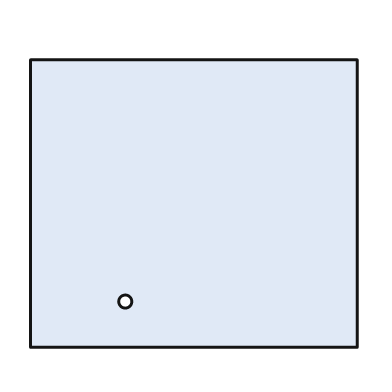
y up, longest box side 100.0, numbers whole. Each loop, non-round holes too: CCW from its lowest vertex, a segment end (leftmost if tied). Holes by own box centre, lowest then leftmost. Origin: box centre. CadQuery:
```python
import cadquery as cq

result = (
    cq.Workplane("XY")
    .moveTo(-50.0, -44.0)
    .lineTo(50.0, -44.0)
    .lineTo(50.0, 44.0)
    .lineTo(-50.0, 44.0)
    .close()
    .moveTo(-21.0, -30.0)
    .circle(2.0)
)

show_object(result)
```